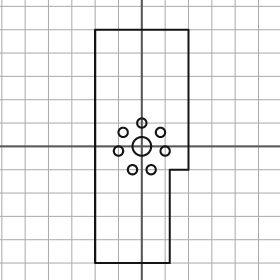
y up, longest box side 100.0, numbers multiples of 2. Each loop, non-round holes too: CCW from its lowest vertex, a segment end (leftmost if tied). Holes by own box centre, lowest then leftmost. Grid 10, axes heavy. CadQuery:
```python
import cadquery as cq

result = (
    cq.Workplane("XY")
    .moveTo(-20.0, -50.0)
    .lineTo(12.0, -50.0)
    .lineTo(12.0, -10.0)
    .lineTo(20.0, -10.0)
    .lineTo(20.0, 50.0)
    .lineTo(-20.0, 50.0)
    .close()
    .moveTo(-4.0, -10.0)
    .circle(2.0)
    .moveTo(4.0, -10.0)
    .circle(2.0)
    .moveTo(-10.0, -2.0)
    .circle(2.0)
    .moveTo(10.0, -2.0)
    .circle(2.0)
    .moveTo(0.0, 0.0)
    .circle(4.0)
    .moveTo(-8.0, 6.0)
    .circle(2.0)
    .moveTo(8.0, 6.0)
    .circle(2.0)
    .moveTo(0.0, 10.0)
    .circle(2.0)
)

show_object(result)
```